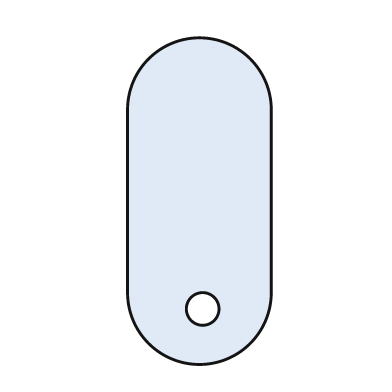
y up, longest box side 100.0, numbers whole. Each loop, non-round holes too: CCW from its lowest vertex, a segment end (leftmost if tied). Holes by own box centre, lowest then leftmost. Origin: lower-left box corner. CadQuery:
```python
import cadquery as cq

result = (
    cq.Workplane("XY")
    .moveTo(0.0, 22.0)
    .threePointArc((22.0, 0.0), (44.0, 22.0))
    .lineTo(44.0, 78.0)
    .threePointArc((22.0, 100.0), (0.0, 78.0))
    .close()
    .moveTo(23.0, 17.0)
    .circle(5.0)
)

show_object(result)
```